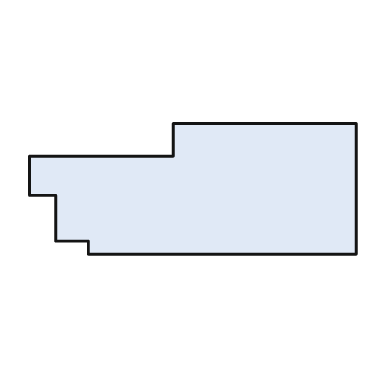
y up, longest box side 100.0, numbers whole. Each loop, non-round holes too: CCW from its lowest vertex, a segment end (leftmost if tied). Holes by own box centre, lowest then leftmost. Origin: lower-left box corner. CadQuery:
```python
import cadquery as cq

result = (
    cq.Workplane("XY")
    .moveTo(18.0, 0.0)
    .lineTo(100.0, 0.0)
    .lineTo(100.0, 40.0)
    .lineTo(44.0, 40.0)
    .lineTo(44.0, 30.0)
    .lineTo(0.0, 30.0)
    .lineTo(0.0, 18.0)
    .lineTo(8.0, 18.0)
    .lineTo(8.0, 4.0)
    .lineTo(18.0, 4.0)
    .close()
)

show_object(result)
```